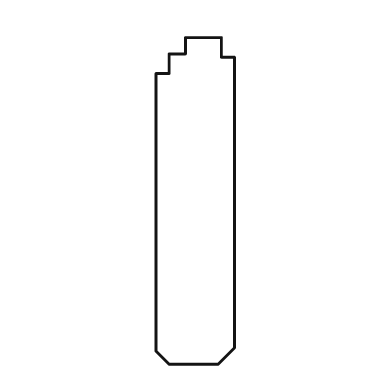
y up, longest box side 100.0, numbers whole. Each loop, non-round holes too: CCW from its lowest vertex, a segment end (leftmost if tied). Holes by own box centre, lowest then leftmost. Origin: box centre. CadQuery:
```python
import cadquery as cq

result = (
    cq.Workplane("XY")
    .moveTo(-8.0, -50.0)
    .lineTo(7.0, -50.0)
    .lineTo(12.0, -45.0)
    .lineTo(12.0, 44.0)
    .lineTo(8.0, 44.0)
    .lineTo(8.0, 50.0)
    .lineTo(-3.0, 50.0)
    .lineTo(-3.0, 45.0)
    .lineTo(-8.0, 45.0)
    .lineTo(-8.0, 39.0)
    .lineTo(-12.0, 39.0)
    .lineTo(-12.0, -46.0)
    .close()
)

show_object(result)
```